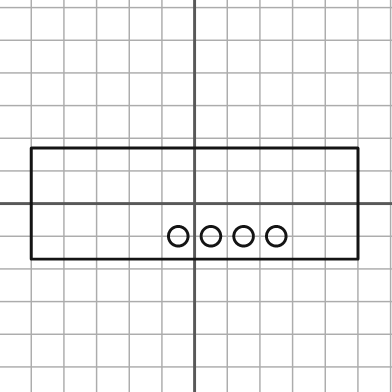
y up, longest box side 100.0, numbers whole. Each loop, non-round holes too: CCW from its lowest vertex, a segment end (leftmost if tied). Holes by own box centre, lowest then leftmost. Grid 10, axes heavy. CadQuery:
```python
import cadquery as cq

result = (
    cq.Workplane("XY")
    .moveTo(-50.0, -17.0)
    .lineTo(50.0, -17.0)
    .lineTo(50.0, 17.0)
    .lineTo(-50.0, 17.0)
    .close()
    .moveTo(-5.0, -10.0)
    .circle(3.0)
    .moveTo(5.0, -10.0)
    .circle(3.0)
    .moveTo(15.0, -10.0)
    .circle(3.0)
    .moveTo(25.0, -10.0)
    .circle(3.0)
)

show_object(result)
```